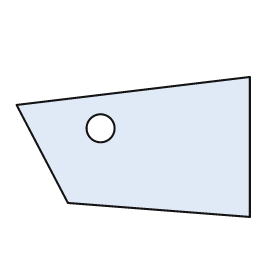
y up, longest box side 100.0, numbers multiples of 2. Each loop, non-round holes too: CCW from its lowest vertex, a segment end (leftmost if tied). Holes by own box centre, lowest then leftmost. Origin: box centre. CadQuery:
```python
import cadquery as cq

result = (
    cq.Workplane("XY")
    .moveTo(50.0, -30.0)
    .lineTo(50.0, 30.0)
    .lineTo(-50.0, 18.0)
    .lineTo(-28.0, -24.0)
    .close()
    .moveTo(-14.0, 8.0)
    .circle(6.0)
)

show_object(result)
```